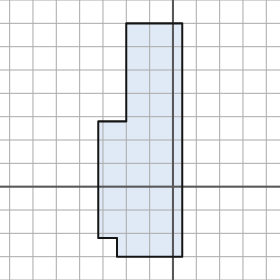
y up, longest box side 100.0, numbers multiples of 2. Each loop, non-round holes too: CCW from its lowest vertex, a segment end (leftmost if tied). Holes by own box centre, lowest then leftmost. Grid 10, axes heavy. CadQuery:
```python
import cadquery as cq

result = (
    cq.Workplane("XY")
    .moveTo(-24.0, -30.0)
    .lineTo(4.0, -30.0)
    .lineTo(4.0, 70.0)
    .lineTo(-20.0, 70.0)
    .lineTo(-20.0, 28.0)
    .lineTo(-32.0, 28.0)
    .lineTo(-32.0, -22.0)
    .lineTo(-24.0, -22.0)
    .close()
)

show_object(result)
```